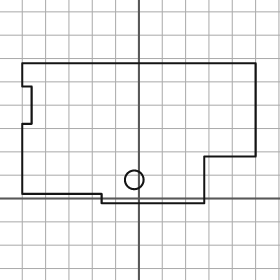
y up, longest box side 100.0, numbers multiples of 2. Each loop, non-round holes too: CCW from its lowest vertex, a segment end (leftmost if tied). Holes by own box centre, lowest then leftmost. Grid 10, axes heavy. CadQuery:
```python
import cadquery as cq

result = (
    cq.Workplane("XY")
    .moveTo(-16.0, -2.0)
    .lineTo(28.0, -2.0)
    .lineTo(28.0, 18.0)
    .lineTo(50.0, 18.0)
    .lineTo(50.0, 58.0)
    .lineTo(-50.0, 58.0)
    .lineTo(-50.0, 48.0)
    .lineTo(-46.0, 48.0)
    .lineTo(-46.0, 32.0)
    .lineTo(-50.0, 32.0)
    .lineTo(-50.0, 2.0)
    .lineTo(-16.0, 2.0)
    .close()
    .moveTo(-2.0, 8.0)
    .circle(4.0)
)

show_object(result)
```